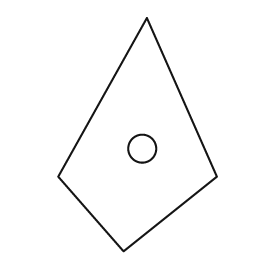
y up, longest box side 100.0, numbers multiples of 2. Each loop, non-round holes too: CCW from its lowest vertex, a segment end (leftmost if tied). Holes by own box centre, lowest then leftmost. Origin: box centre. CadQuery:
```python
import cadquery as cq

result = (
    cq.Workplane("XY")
    .moveTo(-6.0, -50.0)
    .lineTo(34.0, -18.0)
    .lineTo(4.0, 50.0)
    .lineTo(-34.0, -18.0)
    .close()
    .moveTo(2.0, -6.0)
    .circle(6.0)
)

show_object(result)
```